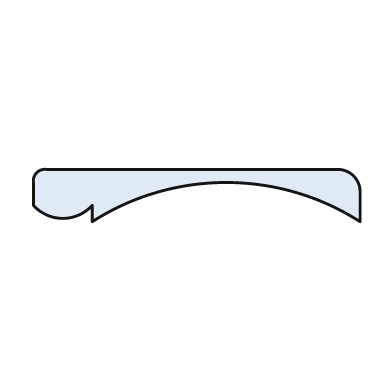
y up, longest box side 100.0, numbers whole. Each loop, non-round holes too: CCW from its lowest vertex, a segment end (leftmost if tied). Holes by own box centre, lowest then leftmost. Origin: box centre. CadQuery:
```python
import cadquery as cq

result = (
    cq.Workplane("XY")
    .moveTo(-32.0, -8.0)
    .threePointArc((9.0, 4.0), (50.0, -8.0))
    .lineTo(50.0, 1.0)
    .threePointArc((48.0, 6.0), (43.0, 8.0))
    .lineTo(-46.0, 8.0)
    .threePointArc((-49.0, 7.0), (-50.0, 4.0))
    .lineTo(-50.0, -3.0)
    .threePointArc((-41.0, -7.0), (-32.0, -3.0))
    .close()
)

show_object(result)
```